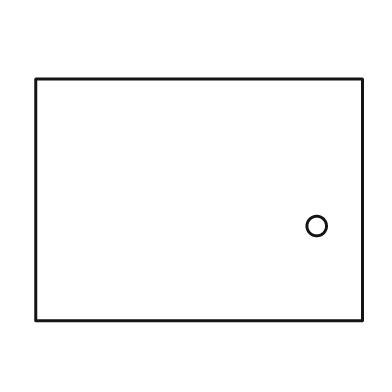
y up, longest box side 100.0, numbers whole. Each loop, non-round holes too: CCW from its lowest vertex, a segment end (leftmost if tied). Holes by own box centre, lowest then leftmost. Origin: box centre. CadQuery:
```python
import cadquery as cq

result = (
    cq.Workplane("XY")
    .moveTo(-50.0, -37.0)
    .lineTo(50.0, -37.0)
    .lineTo(50.0, 37.0)
    .lineTo(-50.0, 37.0)
    .close()
    .moveTo(36.0, -8.0)
    .circle(3.0)
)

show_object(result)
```